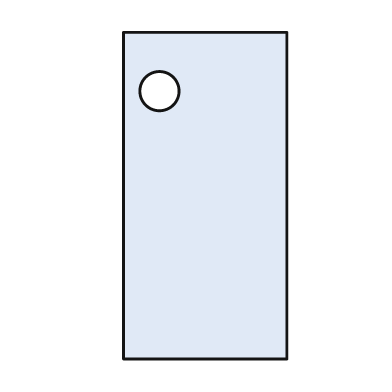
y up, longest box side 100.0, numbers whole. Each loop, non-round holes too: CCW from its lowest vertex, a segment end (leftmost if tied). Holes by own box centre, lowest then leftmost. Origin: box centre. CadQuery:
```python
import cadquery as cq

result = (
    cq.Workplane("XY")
    .moveTo(-25.0, -50.0)
    .lineTo(25.0, -50.0)
    .lineTo(25.0, 50.0)
    .lineTo(-25.0, 50.0)
    .close()
    .moveTo(-14.0, 32.0)
    .circle(6.0)
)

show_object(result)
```